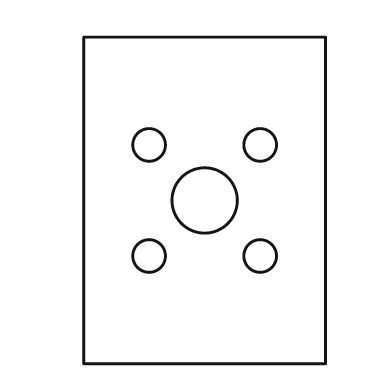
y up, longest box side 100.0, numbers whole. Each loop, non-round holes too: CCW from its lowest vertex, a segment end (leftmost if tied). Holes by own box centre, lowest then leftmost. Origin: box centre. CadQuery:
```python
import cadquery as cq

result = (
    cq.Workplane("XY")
    .moveTo(-37.0, -50.0)
    .lineTo(37.0, -50.0)
    .lineTo(37.0, 50.0)
    .lineTo(-37.0, 50.0)
    .close()
    .moveTo(-17.0, -17.0)
    .circle(5.0)
    .moveTo(17.0, -17.0)
    .circle(5.0)
    .moveTo(0.0, 0.0)
    .circle(10.0)
    .moveTo(-17.0, 17.0)
    .circle(5.0)
    .moveTo(17.0, 17.0)
    .circle(5.0)
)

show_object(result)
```